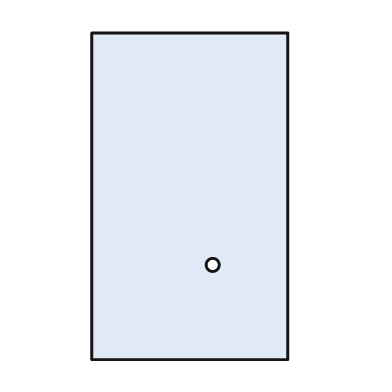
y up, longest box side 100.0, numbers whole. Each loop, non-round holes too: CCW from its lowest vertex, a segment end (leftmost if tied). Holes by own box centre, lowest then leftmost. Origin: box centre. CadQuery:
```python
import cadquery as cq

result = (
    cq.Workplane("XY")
    .moveTo(-30.0, -50.0)
    .lineTo(30.0, -50.0)
    .lineTo(30.0, 50.0)
    .lineTo(-30.0, 50.0)
    .close()
    .moveTo(7.0, -21.0)
    .circle(2.0)
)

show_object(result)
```